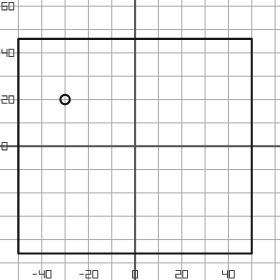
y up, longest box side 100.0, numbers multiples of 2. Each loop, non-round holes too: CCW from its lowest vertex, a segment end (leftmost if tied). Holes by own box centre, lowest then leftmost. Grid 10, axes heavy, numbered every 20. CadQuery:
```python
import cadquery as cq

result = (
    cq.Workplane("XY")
    .moveTo(-50.0, -46.0)
    .lineTo(50.0, -46.0)
    .lineTo(50.0, 46.0)
    .lineTo(-50.0, 46.0)
    .close()
    .moveTo(-30.0, 20.0)
    .circle(2.0)
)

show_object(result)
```